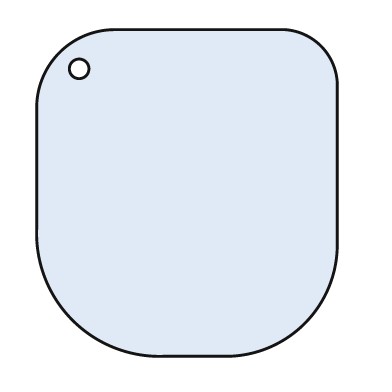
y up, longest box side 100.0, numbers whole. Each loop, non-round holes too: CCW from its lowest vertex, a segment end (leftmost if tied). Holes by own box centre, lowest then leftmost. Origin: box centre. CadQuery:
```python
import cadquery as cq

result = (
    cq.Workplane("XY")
    .moveTo(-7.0, -50.0)
    .lineTo(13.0, -50.0)
    .threePointArc((36.0, -40.0), (46.0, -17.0))
    .lineTo(46.0, 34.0)
    .threePointArc((41.0, 45.0), (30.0, 50.0))
    .lineTo(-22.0, 50.0)
    .threePointArc((-39.0, 43.0), (-46.0, 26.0))
    .lineTo(-46.0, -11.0)
    .threePointArc((-35.0, -39.0), (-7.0, -50.0))
    .close()
    .moveTo(-33.0, 38.0)
    .circle(3.0)
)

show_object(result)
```